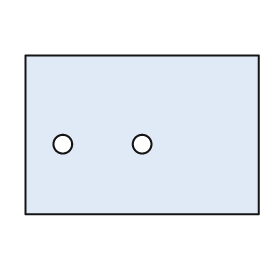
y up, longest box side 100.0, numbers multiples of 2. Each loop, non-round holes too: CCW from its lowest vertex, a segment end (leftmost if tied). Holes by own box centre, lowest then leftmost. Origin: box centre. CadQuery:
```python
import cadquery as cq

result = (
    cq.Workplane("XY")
    .moveTo(-50.0, -34.0)
    .lineTo(50.0, -34.0)
    .lineTo(50.0, 34.0)
    .lineTo(-50.0, 34.0)
    .close()
    .moveTo(-34.0, -4.0)
    .circle(4.0)
    .moveTo(0.0, -4.0)
    .circle(4.0)
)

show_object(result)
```